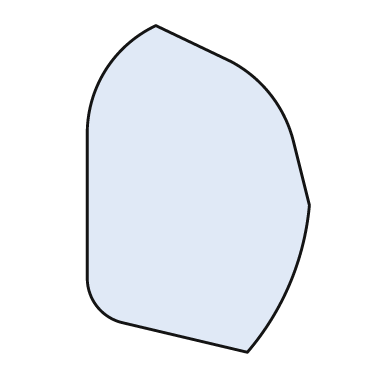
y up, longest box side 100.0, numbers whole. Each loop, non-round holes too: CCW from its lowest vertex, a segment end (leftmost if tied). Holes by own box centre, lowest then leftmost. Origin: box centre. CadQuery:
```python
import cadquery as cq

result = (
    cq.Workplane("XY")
    .moveTo(15.0, -50.0)
    .threePointArc((28.0, -29.0), (34.0, -5.0))
    .lineTo(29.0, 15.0)
    .threePointArc((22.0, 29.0), (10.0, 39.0))
    .lineTo(-13.0, 50.0)
    .threePointArc((-28.0, 37.0), (-34.0, 18.0))
    .lineTo(-34.0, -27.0)
    .threePointArc((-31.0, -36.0), (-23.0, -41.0))
    .close()
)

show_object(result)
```